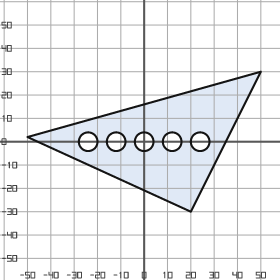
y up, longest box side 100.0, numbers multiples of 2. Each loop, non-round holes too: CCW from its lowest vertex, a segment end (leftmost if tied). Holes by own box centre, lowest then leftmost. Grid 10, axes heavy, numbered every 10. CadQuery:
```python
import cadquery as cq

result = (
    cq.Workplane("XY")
    .moveTo(20.0, -30.0)
    .lineTo(50.0, 30.0)
    .lineTo(-50.0, 2.0)
    .close()
    .moveTo(-24.0, 0.0)
    .circle(4.0)
    .moveTo(-12.0, 0.0)
    .circle(4.0)
    .moveTo(0.0, 0.0)
    .circle(4.0)
    .moveTo(12.0, 0.0)
    .circle(4.0)
    .moveTo(24.0, 0.0)
    .circle(4.0)
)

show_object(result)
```